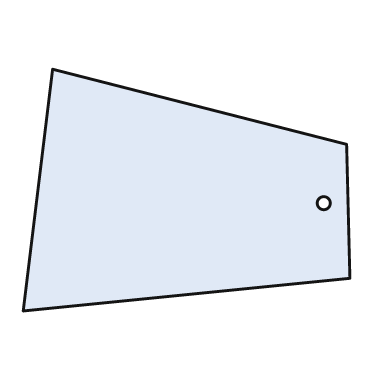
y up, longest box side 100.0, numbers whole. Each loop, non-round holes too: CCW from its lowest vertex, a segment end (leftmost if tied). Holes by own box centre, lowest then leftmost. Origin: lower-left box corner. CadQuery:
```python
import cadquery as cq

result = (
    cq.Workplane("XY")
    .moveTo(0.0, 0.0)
    .lineTo(100.0, 10.0)
    .lineTo(99.0, 51.0)
    .lineTo(9.0, 74.0)
    .close()
    .moveTo(92.0, 33.0)
    .circle(2.0)
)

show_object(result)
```